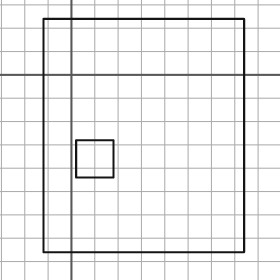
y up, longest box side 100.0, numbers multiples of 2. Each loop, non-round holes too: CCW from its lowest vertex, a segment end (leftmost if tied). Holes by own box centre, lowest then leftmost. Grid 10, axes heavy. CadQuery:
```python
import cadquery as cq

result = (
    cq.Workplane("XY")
    .moveTo(-12.0, -76.0)
    .lineTo(74.0, -76.0)
    .lineTo(74.0, 24.0)
    .lineTo(-12.0, 24.0)
    .close()
    .moveTo(2.0, -44.0)
    .lineTo(18.0, -44.0)
    .lineTo(18.0, -28.0)
    .lineTo(2.0, -28.0)
    .close()
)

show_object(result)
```